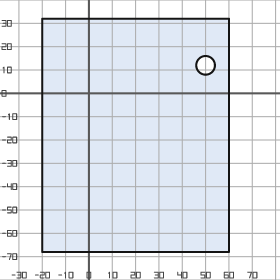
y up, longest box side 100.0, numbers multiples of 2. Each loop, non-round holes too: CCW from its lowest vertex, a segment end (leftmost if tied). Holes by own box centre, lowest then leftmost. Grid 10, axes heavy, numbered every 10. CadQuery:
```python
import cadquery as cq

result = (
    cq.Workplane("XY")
    .moveTo(-20.0, -68.0)
    .lineTo(60.0, -68.0)
    .lineTo(60.0, 32.0)
    .lineTo(-20.0, 32.0)
    .close()
    .moveTo(50.0, 12.0)
    .circle(4.0)
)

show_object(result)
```